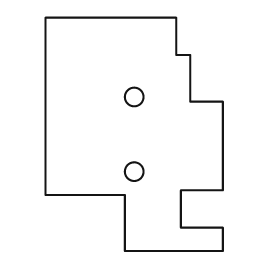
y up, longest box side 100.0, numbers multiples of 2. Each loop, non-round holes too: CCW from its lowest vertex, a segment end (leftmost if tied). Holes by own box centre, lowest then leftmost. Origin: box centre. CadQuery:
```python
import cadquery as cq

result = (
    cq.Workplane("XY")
    .moveTo(-4.0, -50.0)
    .lineTo(38.0, -50.0)
    .lineTo(38.0, -40.0)
    .lineTo(20.0, -40.0)
    .lineTo(20.0, -24.0)
    .lineTo(38.0, -24.0)
    .lineTo(38.0, 14.0)
    .lineTo(24.0, 14.0)
    .lineTo(24.0, 34.0)
    .lineTo(18.0, 34.0)
    .lineTo(18.0, 50.0)
    .lineTo(-38.0, 50.0)
    .lineTo(-38.0, -26.0)
    .lineTo(-4.0, -26.0)
    .close()
    .moveTo(0.0, -16.0)
    .circle(4.0)
    .moveTo(0.0, 16.0)
    .circle(4.0)
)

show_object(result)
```